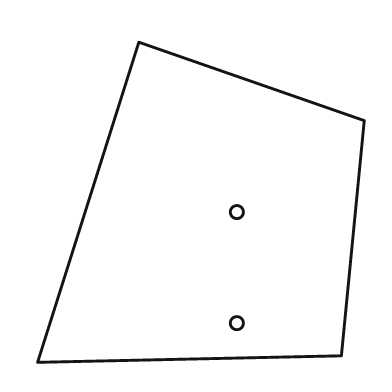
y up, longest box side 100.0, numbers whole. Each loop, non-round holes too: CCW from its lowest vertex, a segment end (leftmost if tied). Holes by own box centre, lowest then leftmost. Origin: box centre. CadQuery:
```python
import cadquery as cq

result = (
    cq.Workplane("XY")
    .moveTo(-50.0, -49.0)
    .lineTo(43.0, -47.0)
    .lineTo(50.0, 25.0)
    .lineTo(-19.0, 49.0)
    .close()
    .moveTo(11.0, -37.0)
    .circle(2.0)
    .moveTo(11.0, -3.0)
    .circle(2.0)
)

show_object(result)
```